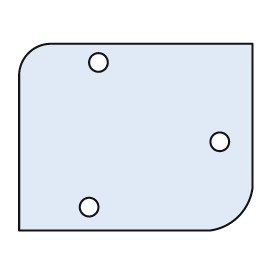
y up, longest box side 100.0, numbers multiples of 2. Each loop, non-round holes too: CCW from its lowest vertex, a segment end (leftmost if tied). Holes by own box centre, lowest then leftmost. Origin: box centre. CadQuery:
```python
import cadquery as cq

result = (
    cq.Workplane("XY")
    .moveTo(-50.0, -40.0)
    .lineTo(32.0, -40.0)
    .threePointArc((44.0, -34.0), (50.0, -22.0))
    .lineTo(50.0, 40.0)
    .lineTo(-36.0, 40.0)
    .threePointArc((-46.0, 36.0), (-50.0, 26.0))
    .close()
    .moveTo(-20.0, -30.0)
    .circle(4.0)
    .moveTo(36.0, -2.0)
    .circle(4.0)
    .moveTo(-16.0, 32.0)
    .circle(4.0)
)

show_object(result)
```